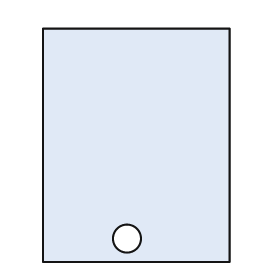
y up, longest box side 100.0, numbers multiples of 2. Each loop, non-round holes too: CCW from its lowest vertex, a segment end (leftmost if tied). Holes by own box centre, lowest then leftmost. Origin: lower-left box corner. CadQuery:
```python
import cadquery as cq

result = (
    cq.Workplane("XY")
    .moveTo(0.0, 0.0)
    .lineTo(80.0, 0.0)
    .lineTo(80.0, 100.0)
    .lineTo(0.0, 100.0)
    .close()
    .moveTo(36.0, 10.0)
    .circle(6.0)
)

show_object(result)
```